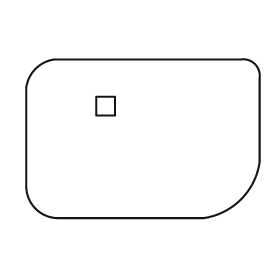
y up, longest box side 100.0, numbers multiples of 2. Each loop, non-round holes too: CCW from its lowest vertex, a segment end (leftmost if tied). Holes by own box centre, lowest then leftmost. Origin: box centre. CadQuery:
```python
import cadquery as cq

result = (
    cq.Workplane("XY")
    .moveTo(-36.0, -34.0)
    .lineTo(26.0, -34.0)
    .threePointArc((42.0, -26.0), (50.0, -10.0))
    .lineTo(50.0, 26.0)
    .threePointArc((48.0, 32.0), (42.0, 34.0))
    .lineTo(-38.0, 34.0)
    .threePointArc((-46.0, 30.0), (-50.0, 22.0))
    .lineTo(-50.0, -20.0)
    .threePointArc((-46.0, -30.0), (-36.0, -34.0))
    .close()
    .moveTo(-20.0, 10.0)
    .lineTo(-12.0, 10.0)
    .lineTo(-12.0, 18.0)
    .lineTo(-20.0, 18.0)
    .close()
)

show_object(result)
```